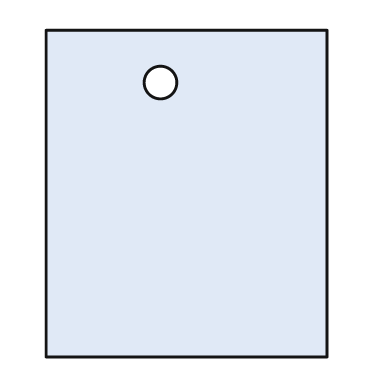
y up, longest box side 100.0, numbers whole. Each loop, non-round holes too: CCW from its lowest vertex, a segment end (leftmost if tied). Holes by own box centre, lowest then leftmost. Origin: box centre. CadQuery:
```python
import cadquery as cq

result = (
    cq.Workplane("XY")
    .moveTo(-43.0, -50.0)
    .lineTo(43.0, -50.0)
    .lineTo(43.0, 50.0)
    .lineTo(-43.0, 50.0)
    .close()
    .moveTo(-8.0, 34.0)
    .circle(5.0)
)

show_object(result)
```